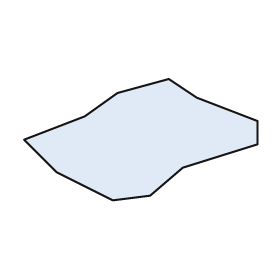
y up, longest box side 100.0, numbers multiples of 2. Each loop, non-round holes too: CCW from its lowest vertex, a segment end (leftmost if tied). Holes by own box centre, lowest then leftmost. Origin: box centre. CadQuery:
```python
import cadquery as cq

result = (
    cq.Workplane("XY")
    .moveTo(-12.0, -26.0)
    .lineTo(4.0, -24.0)
    .lineTo(18.0, -12.0)
    .lineTo(50.0, -2.0)
    .lineTo(50.0, 8.0)
    .lineTo(24.0, 18.0)
    .lineTo(12.0, 26.0)
    .lineTo(-10.0, 20.0)
    .lineTo(-24.0, 10.0)
    .lineTo(-50.0, 0.0)
    .lineTo(-36.0, -14.0)
    .close()
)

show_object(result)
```